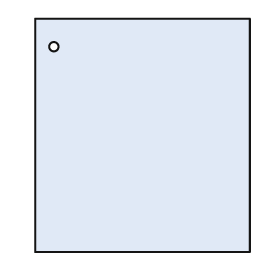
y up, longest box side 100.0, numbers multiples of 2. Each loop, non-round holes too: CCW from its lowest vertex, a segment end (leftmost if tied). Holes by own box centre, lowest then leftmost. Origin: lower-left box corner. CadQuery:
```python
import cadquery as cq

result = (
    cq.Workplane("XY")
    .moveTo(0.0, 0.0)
    .lineTo(92.0, 0.0)
    .lineTo(92.0, 100.0)
    .lineTo(0.0, 100.0)
    .close()
    .moveTo(8.0, 88.0)
    .circle(2.0)
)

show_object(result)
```